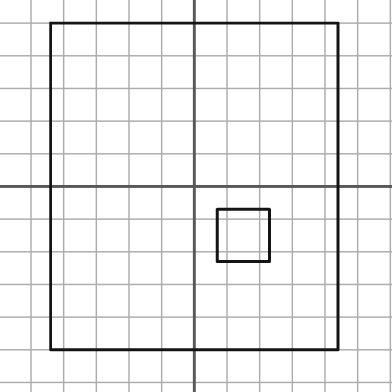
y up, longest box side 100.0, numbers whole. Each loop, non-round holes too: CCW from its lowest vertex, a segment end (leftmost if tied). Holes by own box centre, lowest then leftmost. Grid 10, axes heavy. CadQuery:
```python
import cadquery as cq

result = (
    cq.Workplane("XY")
    .moveTo(-44.0, -50.0)
    .lineTo(44.0, -50.0)
    .lineTo(44.0, 50.0)
    .lineTo(-44.0, 50.0)
    .close()
    .moveTo(7.0, -23.0)
    .lineTo(23.0, -23.0)
    .lineTo(23.0, -7.0)
    .lineTo(7.0, -7.0)
    .close()
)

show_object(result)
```